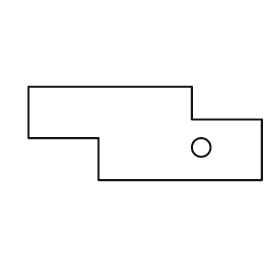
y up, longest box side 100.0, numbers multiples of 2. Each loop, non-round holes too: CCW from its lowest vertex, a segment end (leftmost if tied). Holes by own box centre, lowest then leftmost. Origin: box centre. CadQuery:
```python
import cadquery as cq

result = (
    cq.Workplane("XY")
    .moveTo(-20.0, -20.0)
    .lineTo(50.0, -20.0)
    .lineTo(50.0, 6.0)
    .lineTo(20.0, 6.0)
    .lineTo(20.0, 20.0)
    .lineTo(-50.0, 20.0)
    .lineTo(-50.0, -2.0)
    .lineTo(-20.0, -2.0)
    .close()
    .moveTo(24.0, -6.0)
    .circle(4.0)
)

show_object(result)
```